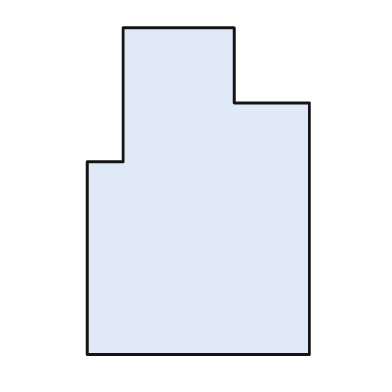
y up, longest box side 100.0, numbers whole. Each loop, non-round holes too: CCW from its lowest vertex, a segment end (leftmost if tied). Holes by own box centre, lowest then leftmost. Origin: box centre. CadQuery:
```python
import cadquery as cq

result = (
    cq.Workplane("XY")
    .moveTo(-34.0, -50.0)
    .lineTo(34.0, -50.0)
    .lineTo(34.0, 27.0)
    .lineTo(11.0, 27.0)
    .lineTo(11.0, 50.0)
    .lineTo(-23.0, 50.0)
    .lineTo(-23.0, 9.0)
    .lineTo(-34.0, 9.0)
    .close()
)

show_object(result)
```